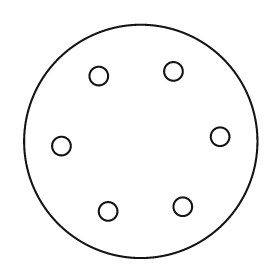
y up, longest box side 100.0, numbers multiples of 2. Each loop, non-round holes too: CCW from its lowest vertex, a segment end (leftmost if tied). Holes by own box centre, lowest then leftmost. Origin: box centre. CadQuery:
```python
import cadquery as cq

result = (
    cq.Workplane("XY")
    .moveTo(0.0, 0.0)
    .circle(50.0)
    .moveTo(-14.0, -30.0)
    .circle(4.0)
    .moveTo(18.0, -28.0)
    .circle(4.0)
    .moveTo(-34.0, -2.0)
    .circle(4.0)
    .moveTo(34.0, 2.0)
    .circle(4.0)
    .moveTo(-18.0, 28.0)
    .circle(4.0)
    .moveTo(14.0, 30.0)
    .circle(4.0)
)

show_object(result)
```